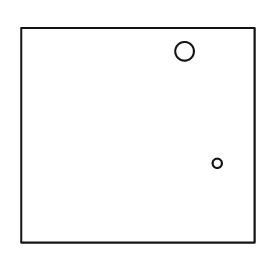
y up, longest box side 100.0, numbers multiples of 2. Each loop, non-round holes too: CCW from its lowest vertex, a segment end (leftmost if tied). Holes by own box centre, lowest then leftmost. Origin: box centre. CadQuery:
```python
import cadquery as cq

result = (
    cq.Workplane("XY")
    .moveTo(-50.0, -46.0)
    .lineTo(50.0, -46.0)
    .lineTo(50.0, 46.0)
    .lineTo(-50.0, 46.0)
    .close()
    .moveTo(34.0, -12.0)
    .circle(2.0)
    .moveTo(20.0, 36.0)
    .circle(4.0)
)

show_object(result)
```